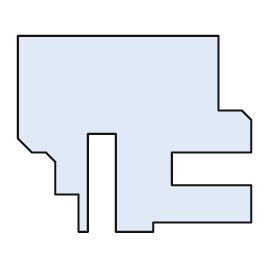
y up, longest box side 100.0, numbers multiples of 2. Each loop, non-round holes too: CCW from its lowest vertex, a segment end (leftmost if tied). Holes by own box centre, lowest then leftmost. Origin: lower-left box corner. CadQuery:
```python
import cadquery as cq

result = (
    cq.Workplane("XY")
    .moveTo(26.0, 0.0)
    .lineTo(30.0, 0.0)
    .lineTo(30.0, 42.0)
    .lineTo(42.0, 42.0)
    .lineTo(42.0, 0.0)
    .lineTo(58.0, 0.0)
    .lineTo(58.0, 4.0)
    .lineTo(100.0, 4.0)
    .lineTo(100.0, 20.0)
    .lineTo(66.0, 20.0)
    .lineTo(66.0, 34.0)
    .lineTo(100.0, 34.0)
    .lineTo(100.0, 48.0)
    .lineTo(96.0, 52.0)
    .lineTo(86.0, 52.0)
    .lineTo(86.0, 84.0)
    .lineTo(0.0, 84.0)
    .lineTo(0.0, 40.0)
    .lineTo(6.0, 34.0)
    .lineTo(12.0, 34.0)
    .lineTo(16.0, 30.0)
    .lineTo(16.0, 16.0)
    .lineTo(26.0, 16.0)
    .close()
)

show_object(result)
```